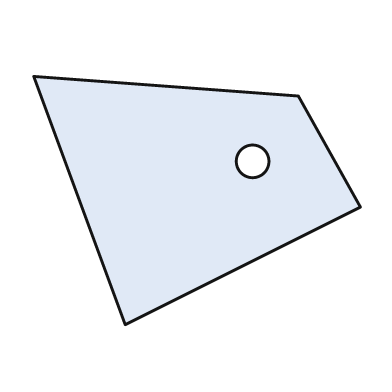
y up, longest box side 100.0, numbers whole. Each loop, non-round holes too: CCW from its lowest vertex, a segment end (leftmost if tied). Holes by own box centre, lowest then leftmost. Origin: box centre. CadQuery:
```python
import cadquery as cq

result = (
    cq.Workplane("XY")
    .moveTo(-22.0, -38.0)
    .lineTo(50.0, -2.0)
    .lineTo(31.0, 32.0)
    .lineTo(-50.0, 38.0)
    .close()
    .moveTo(17.0, 12.0)
    .circle(5.0)
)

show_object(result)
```